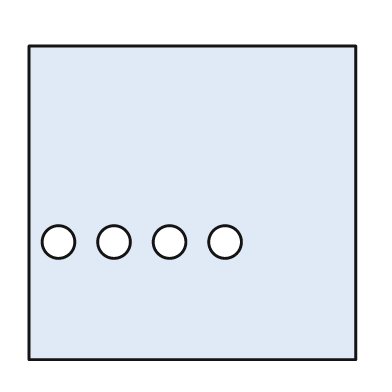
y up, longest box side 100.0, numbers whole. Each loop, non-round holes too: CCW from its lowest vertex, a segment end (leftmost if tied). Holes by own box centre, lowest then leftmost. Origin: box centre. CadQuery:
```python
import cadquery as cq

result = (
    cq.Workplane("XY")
    .moveTo(-50.0, -48.0)
    .lineTo(50.0, -48.0)
    .lineTo(50.0, 48.0)
    .lineTo(-50.0, 48.0)
    .close()
    .moveTo(-41.0, -12.0)
    .circle(5.0)
    .moveTo(-24.0, -12.0)
    .circle(5.0)
    .moveTo(-7.0, -12.0)
    .circle(5.0)
    .moveTo(10.0, -12.0)
    .circle(5.0)
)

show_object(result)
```